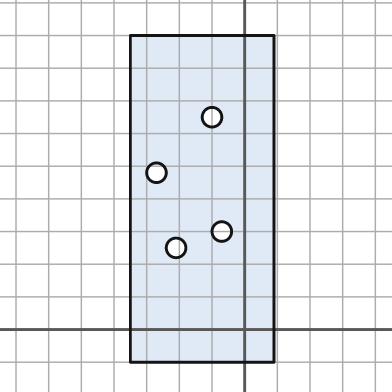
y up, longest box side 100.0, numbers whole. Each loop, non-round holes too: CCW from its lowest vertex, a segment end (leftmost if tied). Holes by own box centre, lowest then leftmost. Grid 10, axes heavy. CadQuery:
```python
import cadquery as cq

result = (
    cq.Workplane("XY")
    .moveTo(-35.0, -10.0)
    .lineTo(9.0, -10.0)
    .lineTo(9.0, 90.0)
    .lineTo(-35.0, 90.0)
    .close()
    .moveTo(-21.0, 25.0)
    .circle(3.0)
    .moveTo(-7.0, 30.0)
    .circle(3.0)
    .moveTo(-27.0, 48.0)
    .circle(3.0)
    .moveTo(-10.0, 65.0)
    .circle(3.0)
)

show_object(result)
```